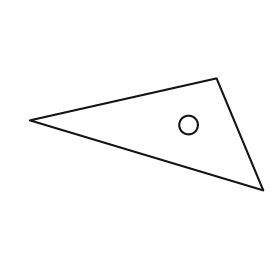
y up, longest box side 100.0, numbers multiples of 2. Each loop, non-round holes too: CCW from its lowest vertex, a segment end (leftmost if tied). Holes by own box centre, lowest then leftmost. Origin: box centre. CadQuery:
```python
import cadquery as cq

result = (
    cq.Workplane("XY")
    .moveTo(50.0, -24.0)
    .lineTo(30.0, 24.0)
    .lineTo(-50.0, 6.0)
    .close()
    .moveTo(18.0, 4.0)
    .circle(4.0)
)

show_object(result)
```